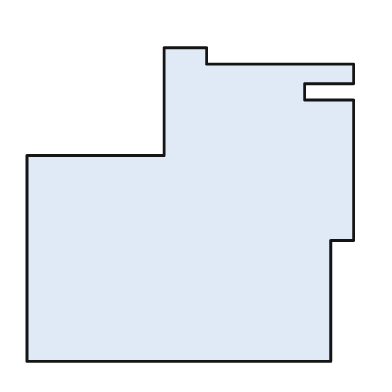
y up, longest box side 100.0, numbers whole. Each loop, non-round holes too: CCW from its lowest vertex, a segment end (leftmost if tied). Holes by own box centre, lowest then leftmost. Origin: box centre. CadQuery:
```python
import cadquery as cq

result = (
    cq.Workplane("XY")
    .moveTo(-50.0, -48.0)
    .lineTo(43.0, -48.0)
    .lineTo(43.0, -11.0)
    .lineTo(50.0, -11.0)
    .lineTo(50.0, 32.0)
    .lineTo(35.0, 32.0)
    .lineTo(35.0, 37.0)
    .lineTo(50.0, 37.0)
    .lineTo(50.0, 43.0)
    .lineTo(5.0, 43.0)
    .lineTo(5.0, 48.0)
    .lineTo(-8.0, 48.0)
    .lineTo(-8.0, 15.0)
    .lineTo(-50.0, 15.0)
    .close()
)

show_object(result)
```